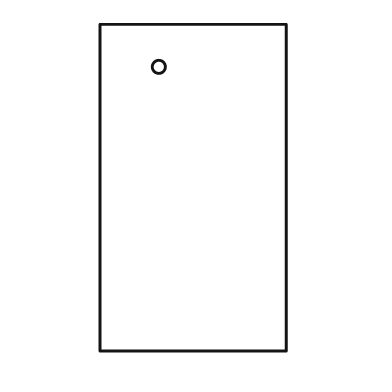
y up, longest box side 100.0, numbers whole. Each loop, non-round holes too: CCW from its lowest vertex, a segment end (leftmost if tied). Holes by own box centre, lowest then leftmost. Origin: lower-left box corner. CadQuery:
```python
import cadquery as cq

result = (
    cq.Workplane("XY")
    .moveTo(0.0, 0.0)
    .lineTo(57.0, 0.0)
    .lineTo(57.0, 100.0)
    .lineTo(0.0, 100.0)
    .close()
    .moveTo(18.0, 87.0)
    .circle(2.0)
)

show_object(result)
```